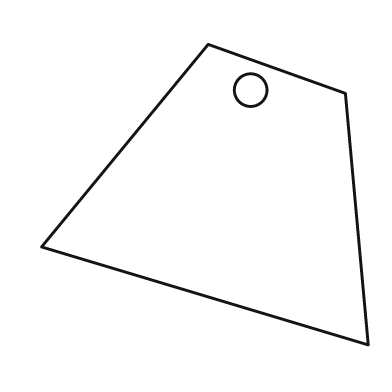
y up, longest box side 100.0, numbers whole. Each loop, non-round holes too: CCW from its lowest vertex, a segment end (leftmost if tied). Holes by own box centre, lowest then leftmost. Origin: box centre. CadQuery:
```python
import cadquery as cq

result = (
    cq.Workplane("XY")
    .moveTo(50.0, -46.0)
    .lineTo(43.0, 31.0)
    .lineTo(1.0, 46.0)
    .lineTo(-50.0, -16.0)
    .close()
    .moveTo(14.0, 32.0)
    .circle(5.0)
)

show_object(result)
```